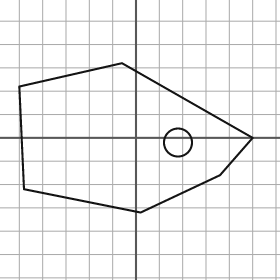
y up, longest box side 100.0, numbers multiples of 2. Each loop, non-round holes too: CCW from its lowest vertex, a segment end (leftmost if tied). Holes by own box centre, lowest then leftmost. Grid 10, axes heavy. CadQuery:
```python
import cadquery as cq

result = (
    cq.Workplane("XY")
    .moveTo(2.0, -32.0)
    .lineTo(36.0, -16.0)
    .lineTo(50.0, 0.0)
    .lineTo(-6.0, 32.0)
    .lineTo(-50.0, 22.0)
    .lineTo(-48.0, -22.0)
    .close()
    .moveTo(18.0, -2.0)
    .circle(6.0)
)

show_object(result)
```